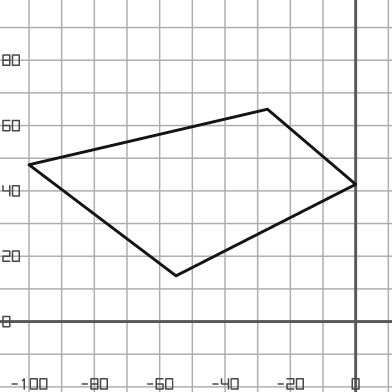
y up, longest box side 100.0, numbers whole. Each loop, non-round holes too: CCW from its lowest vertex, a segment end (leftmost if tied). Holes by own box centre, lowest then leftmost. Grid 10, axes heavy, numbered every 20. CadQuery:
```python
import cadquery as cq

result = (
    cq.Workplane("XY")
    .moveTo(-55.0, 14.0)
    .lineTo(0.0, 42.0)
    .lineTo(-27.0, 65.0)
    .lineTo(-100.0, 48.0)
    .close()
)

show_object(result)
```